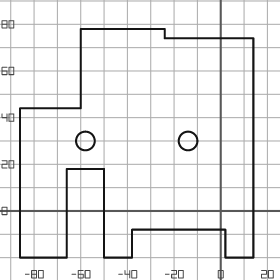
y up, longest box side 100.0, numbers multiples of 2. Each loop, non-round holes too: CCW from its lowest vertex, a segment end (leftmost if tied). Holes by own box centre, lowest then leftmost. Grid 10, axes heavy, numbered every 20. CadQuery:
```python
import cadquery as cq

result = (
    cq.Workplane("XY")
    .moveTo(-86.0, -20.0)
    .lineTo(-66.0, -20.0)
    .lineTo(-66.0, 18.0)
    .lineTo(-50.0, 18.0)
    .lineTo(-50.0, -20.0)
    .lineTo(-38.0, -20.0)
    .lineTo(-38.0, -8.0)
    .lineTo(2.0, -8.0)
    .lineTo(2.0, -20.0)
    .lineTo(14.0, -20.0)
    .lineTo(14.0, 74.0)
    .lineTo(-24.0, 74.0)
    .lineTo(-24.0, 78.0)
    .lineTo(-60.0, 78.0)
    .lineTo(-60.0, 44.0)
    .lineTo(-86.0, 44.0)
    .close()
    .moveTo(-58.0, 30.0)
    .circle(4.0)
    .moveTo(-14.0, 30.0)
    .circle(4.0)
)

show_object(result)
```